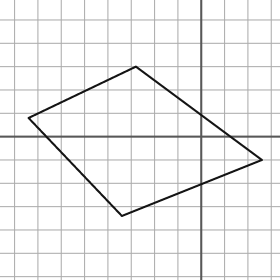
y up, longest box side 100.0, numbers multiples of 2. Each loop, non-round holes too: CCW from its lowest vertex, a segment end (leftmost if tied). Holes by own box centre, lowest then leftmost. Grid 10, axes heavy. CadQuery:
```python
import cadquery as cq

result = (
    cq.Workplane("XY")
    .moveTo(-34.0, -34.0)
    .lineTo(26.0, -10.0)
    .lineTo(-28.0, 30.0)
    .lineTo(-74.0, 8.0)
    .close()
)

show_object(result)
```